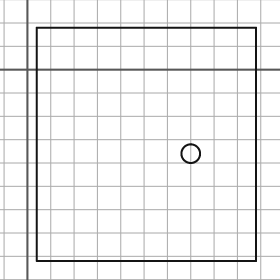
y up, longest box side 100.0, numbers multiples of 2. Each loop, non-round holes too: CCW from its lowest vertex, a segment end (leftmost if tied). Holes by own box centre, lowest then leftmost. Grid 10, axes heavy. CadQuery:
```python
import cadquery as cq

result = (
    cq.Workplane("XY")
    .moveTo(4.0, -82.0)
    .lineTo(98.0, -82.0)
    .lineTo(98.0, 18.0)
    .lineTo(4.0, 18.0)
    .close()
    .moveTo(70.0, -36.0)
    .circle(4.0)
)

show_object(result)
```